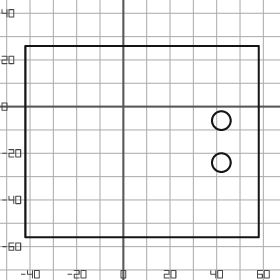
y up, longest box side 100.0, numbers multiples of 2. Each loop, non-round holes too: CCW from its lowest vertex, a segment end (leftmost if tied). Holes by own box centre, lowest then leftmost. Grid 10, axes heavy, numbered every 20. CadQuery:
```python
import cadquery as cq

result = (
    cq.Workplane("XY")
    .moveTo(-42.0, -56.0)
    .lineTo(58.0, -56.0)
    .lineTo(58.0, 26.0)
    .lineTo(-42.0, 26.0)
    .close()
    .moveTo(42.0, -24.0)
    .circle(4.0)
    .moveTo(42.0, -6.0)
    .circle(4.0)
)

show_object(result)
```